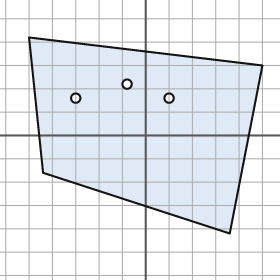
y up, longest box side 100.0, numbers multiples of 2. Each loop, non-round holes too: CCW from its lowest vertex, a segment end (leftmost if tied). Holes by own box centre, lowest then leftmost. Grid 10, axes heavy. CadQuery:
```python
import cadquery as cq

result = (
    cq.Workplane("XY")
    .moveTo(36.0, -42.0)
    .lineTo(50.0, 30.0)
    .lineTo(-50.0, 42.0)
    .lineTo(-44.0, -16.0)
    .close()
    .moveTo(-30.0, 16.0)
    .circle(2.0)
    .moveTo(10.0, 16.0)
    .circle(2.0)
    .moveTo(-8.0, 22.0)
    .circle(2.0)
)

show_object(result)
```